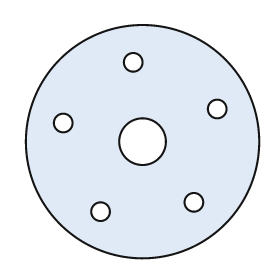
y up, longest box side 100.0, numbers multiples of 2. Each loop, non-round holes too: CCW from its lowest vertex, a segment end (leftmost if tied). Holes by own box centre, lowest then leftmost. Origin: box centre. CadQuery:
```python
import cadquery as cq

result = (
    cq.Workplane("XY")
    .moveTo(0.0, 0.0)
    .circle(50.0)
    .moveTo(-18.0, -30.0)
    .circle(4.0)
    .moveTo(22.0, -26.0)
    .circle(4.0)
    .moveTo(0.0, 0.0)
    .circle(10.0)
    .moveTo(-34.0, 8.0)
    .circle(4.0)
    .moveTo(32.0, 14.0)
    .circle(4.0)
    .moveTo(-4.0, 34.0)
    .circle(4.0)
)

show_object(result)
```